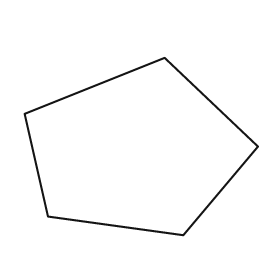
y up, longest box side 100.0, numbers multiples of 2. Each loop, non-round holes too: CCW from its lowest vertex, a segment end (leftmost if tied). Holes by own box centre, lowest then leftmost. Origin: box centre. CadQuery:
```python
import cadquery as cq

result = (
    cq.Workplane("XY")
    .moveTo(18.0, -38.0)
    .lineTo(50.0, 0.0)
    .lineTo(10.0, 38.0)
    .lineTo(-50.0, 14.0)
    .lineTo(-40.0, -30.0)
    .close()
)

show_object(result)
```